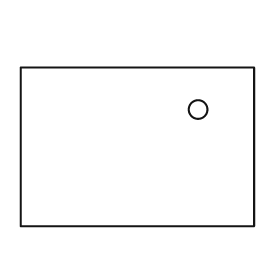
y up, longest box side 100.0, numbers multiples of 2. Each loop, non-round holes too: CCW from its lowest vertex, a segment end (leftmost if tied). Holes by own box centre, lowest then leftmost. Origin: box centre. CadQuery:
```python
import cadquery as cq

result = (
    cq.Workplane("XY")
    .moveTo(-50.0, -34.0)
    .lineTo(50.0, -34.0)
    .lineTo(50.0, 34.0)
    .lineTo(-50.0, 34.0)
    .close()
    .moveTo(26.0, 16.0)
    .circle(4.0)
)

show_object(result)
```